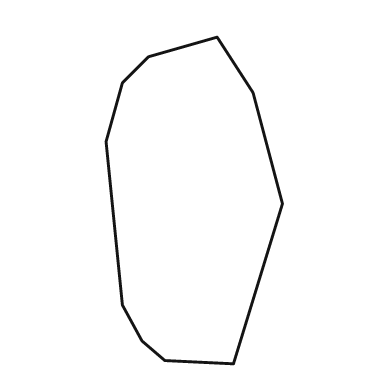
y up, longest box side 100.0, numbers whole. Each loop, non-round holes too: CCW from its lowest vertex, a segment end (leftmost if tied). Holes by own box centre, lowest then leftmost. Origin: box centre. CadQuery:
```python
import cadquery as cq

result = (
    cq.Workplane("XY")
    .moveTo(12.0, -50.0)
    .lineTo(27.0, -1.0)
    .lineTo(18.0, 33.0)
    .lineTo(7.0, 50.0)
    .lineTo(-14.0, 44.0)
    .lineTo(-22.0, 36.0)
    .lineTo(-27.0, 18.0)
    .lineTo(-22.0, -32.0)
    .lineTo(-16.0, -43.0)
    .lineTo(-9.0, -49.0)
    .close()
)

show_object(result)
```